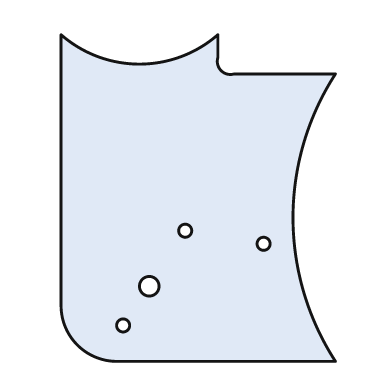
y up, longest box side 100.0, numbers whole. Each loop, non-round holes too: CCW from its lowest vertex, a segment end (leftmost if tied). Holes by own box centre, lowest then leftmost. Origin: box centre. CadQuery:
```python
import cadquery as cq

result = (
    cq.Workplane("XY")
    .moveTo(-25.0, -50.0)
    .lineTo(42.0, -50.0)
    .threePointArc((29.0, -6.0), (42.0, 38.0))
    .lineTo(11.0, 38.0)
    .threePointArc((7.0, 39.0), (6.0, 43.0))
    .lineTo(6.0, 50.0)
    .threePointArc((-18.0, 41.0), (-42.0, 50.0))
    .lineTo(-42.0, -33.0)
    .threePointArc((-37.0, -45.0), (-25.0, -50.0))
    .close()
    .moveTo(-23.0, -39.0)
    .circle(2.0)
    .moveTo(-15.0, -27.0)
    .circle(3.0)
    .moveTo(20.0, -14.0)
    .circle(2.0)
    .moveTo(-4.0, -10.0)
    .circle(2.0)
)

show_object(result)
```